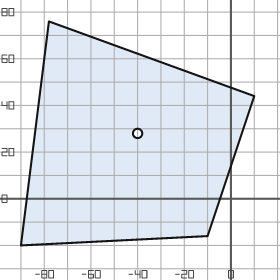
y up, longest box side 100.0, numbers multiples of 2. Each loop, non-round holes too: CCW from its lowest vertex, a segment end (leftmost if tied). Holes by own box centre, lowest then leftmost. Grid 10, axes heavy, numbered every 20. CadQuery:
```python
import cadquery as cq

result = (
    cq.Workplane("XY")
    .moveTo(-90.0, -20.0)
    .lineTo(-10.0, -16.0)
    .lineTo(10.0, 44.0)
    .lineTo(-78.0, 76.0)
    .close()
    .moveTo(-40.0, 28.0)
    .circle(2.0)
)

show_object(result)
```